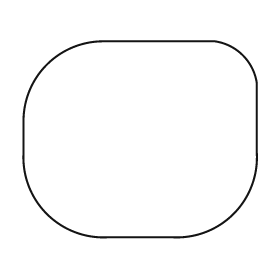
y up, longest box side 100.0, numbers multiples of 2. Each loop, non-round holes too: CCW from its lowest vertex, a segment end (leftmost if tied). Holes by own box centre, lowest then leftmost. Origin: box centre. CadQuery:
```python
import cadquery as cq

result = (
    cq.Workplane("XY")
    .moveTo(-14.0, -42.0)
    .lineTo(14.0, -42.0)
    .threePointArc((40.0, -32.0), (50.0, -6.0))
    .lineTo(50.0, 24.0)
    .threePointArc((44.0, 36.0), (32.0, 42.0))
    .lineTo(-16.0, 42.0)
    .threePointArc((-40.0, 32.0), (-50.0, 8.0))
    .lineTo(-50.0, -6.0)
    .threePointArc((-40.0, -32.0), (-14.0, -42.0))
    .close()
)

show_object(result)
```